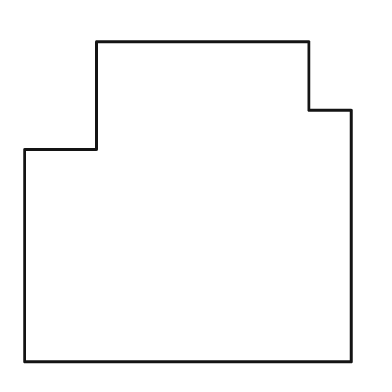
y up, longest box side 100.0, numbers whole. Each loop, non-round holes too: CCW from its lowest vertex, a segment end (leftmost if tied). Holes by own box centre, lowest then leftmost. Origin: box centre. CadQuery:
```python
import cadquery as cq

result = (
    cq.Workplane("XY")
    .moveTo(-50.0, -49.0)
    .lineTo(50.0, -49.0)
    .lineTo(50.0, 28.0)
    .lineTo(37.0, 28.0)
    .lineTo(37.0, 49.0)
    .lineTo(-28.0, 49.0)
    .lineTo(-28.0, 16.0)
    .lineTo(-50.0, 16.0)
    .close()
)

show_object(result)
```